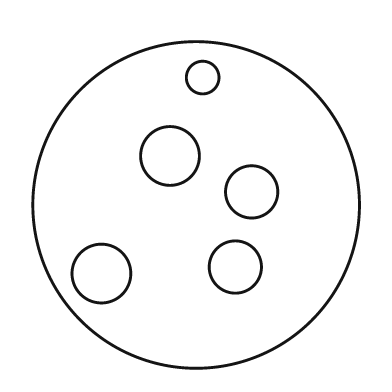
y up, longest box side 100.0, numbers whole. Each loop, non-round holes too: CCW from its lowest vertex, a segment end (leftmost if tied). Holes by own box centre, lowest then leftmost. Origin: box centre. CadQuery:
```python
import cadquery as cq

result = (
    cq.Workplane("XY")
    .moveTo(0.0, 0.0)
    .circle(50.0)
    .moveTo(-29.0, -21.0)
    .circle(9.0)
    .moveTo(12.0, -19.0)
    .circle(8.0)
    .moveTo(17.0, 4.0)
    .circle(8.0)
    .moveTo(-8.0, 15.0)
    .circle(9.0)
    .moveTo(2.0, 39.0)
    .circle(5.0)
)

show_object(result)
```